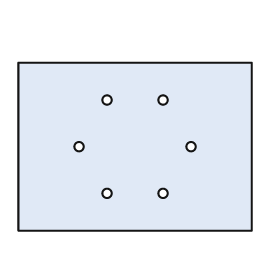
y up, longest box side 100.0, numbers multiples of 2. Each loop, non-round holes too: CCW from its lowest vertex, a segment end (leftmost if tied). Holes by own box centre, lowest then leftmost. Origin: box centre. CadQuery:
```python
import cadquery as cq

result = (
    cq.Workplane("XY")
    .moveTo(-50.0, -36.0)
    .lineTo(50.0, -36.0)
    .lineTo(50.0, 36.0)
    .lineTo(-50.0, 36.0)
    .close()
    .moveTo(-12.0, -20.0)
    .circle(2.0)
    .moveTo(12.0, -20.0)
    .circle(2.0)
    .moveTo(-24.0, 0.0)
    .circle(2.0)
    .moveTo(24.0, 0.0)
    .circle(2.0)
    .moveTo(-12.0, 20.0)
    .circle(2.0)
    .moveTo(12.0, 20.0)
    .circle(2.0)
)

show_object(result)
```